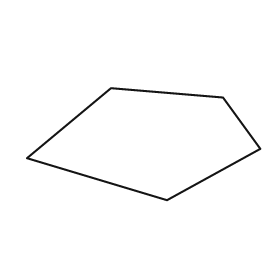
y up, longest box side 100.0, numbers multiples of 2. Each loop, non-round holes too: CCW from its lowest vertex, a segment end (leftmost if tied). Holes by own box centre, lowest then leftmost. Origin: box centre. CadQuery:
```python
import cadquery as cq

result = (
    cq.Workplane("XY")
    .moveTo(10.0, -24.0)
    .lineTo(50.0, -2.0)
    .lineTo(34.0, 20.0)
    .lineTo(-14.0, 24.0)
    .lineTo(-50.0, -6.0)
    .close()
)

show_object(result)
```